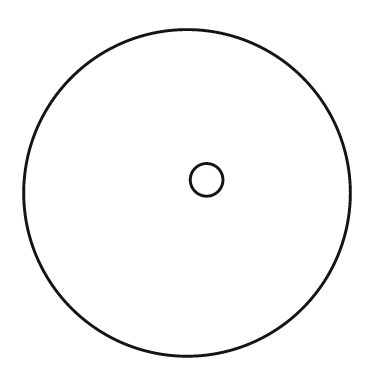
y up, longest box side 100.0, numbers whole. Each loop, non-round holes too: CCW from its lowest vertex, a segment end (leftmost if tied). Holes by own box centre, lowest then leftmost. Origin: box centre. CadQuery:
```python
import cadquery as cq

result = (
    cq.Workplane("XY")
    .moveTo(0.0, 0.0)
    .circle(50.0)
    .moveTo(6.0, 4.0)
    .circle(5.0)
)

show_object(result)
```